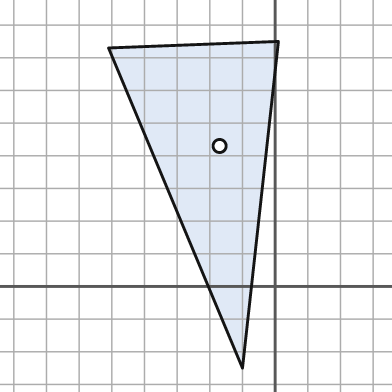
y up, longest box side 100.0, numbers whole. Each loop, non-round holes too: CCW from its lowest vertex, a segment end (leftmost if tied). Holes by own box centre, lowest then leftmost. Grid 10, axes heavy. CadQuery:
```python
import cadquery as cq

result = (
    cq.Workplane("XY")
    .moveTo(-10.0, -25.0)
    .lineTo(1.0, 75.0)
    .lineTo(-51.0, 73.0)
    .close()
    .moveTo(-17.0, 43.0)
    .circle(2.0)
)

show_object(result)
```